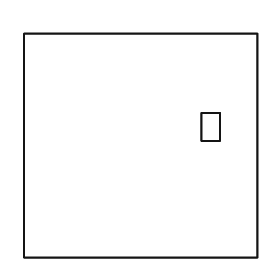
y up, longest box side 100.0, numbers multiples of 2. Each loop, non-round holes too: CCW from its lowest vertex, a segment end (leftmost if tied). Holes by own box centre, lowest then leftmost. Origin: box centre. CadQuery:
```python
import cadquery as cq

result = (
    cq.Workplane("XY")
    .moveTo(-50.0, -48.0)
    .lineTo(50.0, -48.0)
    .lineTo(50.0, 48.0)
    .lineTo(-50.0, 48.0)
    .close()
    .moveTo(26.0, 2.0)
    .lineTo(34.0, 2.0)
    .lineTo(34.0, 14.0)
    .lineTo(26.0, 14.0)
    .close()
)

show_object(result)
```